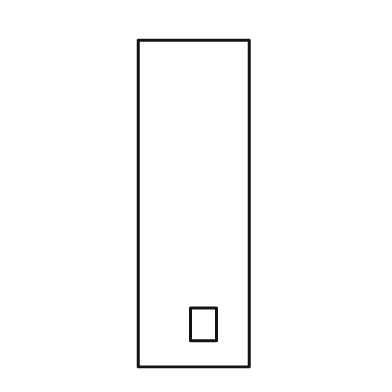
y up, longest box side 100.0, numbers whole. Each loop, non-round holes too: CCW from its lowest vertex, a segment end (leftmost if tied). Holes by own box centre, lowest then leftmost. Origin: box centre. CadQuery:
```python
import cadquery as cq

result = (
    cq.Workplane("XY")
    .moveTo(-17.0, -50.0)
    .lineTo(17.0, -50.0)
    .lineTo(17.0, 50.0)
    .lineTo(-17.0, 50.0)
    .close()
    .moveTo(-1.0, -42.0)
    .lineTo(7.0, -42.0)
    .lineTo(7.0, -32.0)
    .lineTo(-1.0, -32.0)
    .close()
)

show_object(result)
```